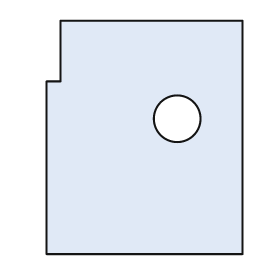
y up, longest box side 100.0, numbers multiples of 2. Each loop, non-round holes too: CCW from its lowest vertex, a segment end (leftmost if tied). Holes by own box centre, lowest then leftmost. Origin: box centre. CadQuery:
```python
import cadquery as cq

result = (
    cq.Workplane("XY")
    .moveTo(-42.0, -50.0)
    .lineTo(42.0, -50.0)
    .lineTo(42.0, 50.0)
    .lineTo(-36.0, 50.0)
    .lineTo(-36.0, 24.0)
    .lineTo(-42.0, 24.0)
    .close()
    .moveTo(14.0, 8.0)
    .circle(10.0)
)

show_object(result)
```